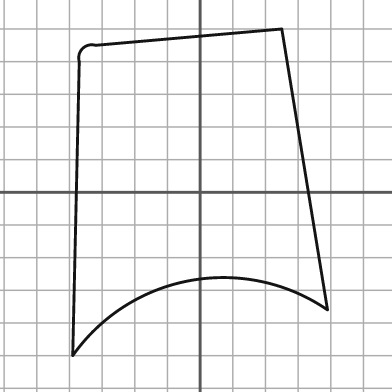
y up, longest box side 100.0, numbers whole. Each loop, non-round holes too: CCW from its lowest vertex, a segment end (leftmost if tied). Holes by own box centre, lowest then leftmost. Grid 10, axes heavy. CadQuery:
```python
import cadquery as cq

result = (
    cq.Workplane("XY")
    .moveTo(-39.0, -50.0)
    .threePointArc((-3.0, -27.0), (39.0, -36.0))
    .lineTo(25.0, 50.0)
    .lineTo(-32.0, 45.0)
    .threePointArc((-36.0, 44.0), (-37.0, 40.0))
    .close()
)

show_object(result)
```